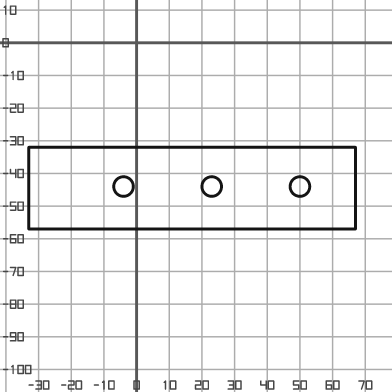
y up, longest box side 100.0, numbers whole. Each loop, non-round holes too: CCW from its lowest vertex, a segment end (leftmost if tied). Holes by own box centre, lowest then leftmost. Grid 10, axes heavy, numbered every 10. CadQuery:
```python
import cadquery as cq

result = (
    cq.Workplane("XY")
    .moveTo(-33.0, -57.0)
    .lineTo(67.0, -57.0)
    .lineTo(67.0, -32.0)
    .lineTo(-33.0, -32.0)
    .close()
    .moveTo(-4.0, -44.0)
    .circle(3.0)
    .moveTo(23.0, -44.0)
    .circle(3.0)
    .moveTo(50.0, -44.0)
    .circle(3.0)
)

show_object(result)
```